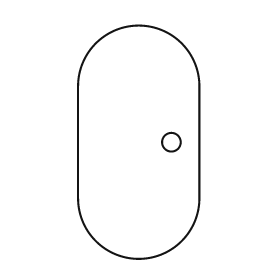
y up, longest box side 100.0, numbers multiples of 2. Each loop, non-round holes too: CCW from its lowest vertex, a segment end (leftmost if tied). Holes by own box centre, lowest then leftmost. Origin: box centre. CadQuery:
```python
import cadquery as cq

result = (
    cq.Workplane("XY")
    .moveTo(-26.0, -24.0)
    .threePointArc((0.0, -50.0), (26.0, -24.0))
    .lineTo(26.0, 24.0)
    .threePointArc((0.0, 50.0), (-26.0, 24.0))
    .close()
    .moveTo(14.0, 0.0)
    .circle(4.0)
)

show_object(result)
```